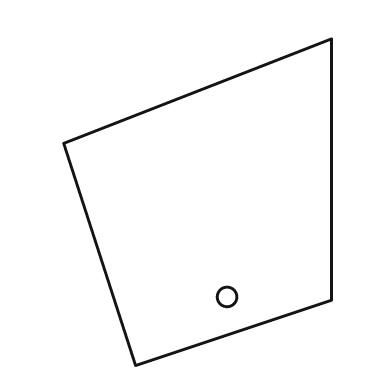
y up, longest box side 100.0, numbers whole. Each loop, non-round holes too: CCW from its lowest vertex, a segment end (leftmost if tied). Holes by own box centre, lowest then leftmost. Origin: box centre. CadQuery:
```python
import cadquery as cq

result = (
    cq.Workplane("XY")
    .moveTo(-19.0, -50.0)
    .lineTo(41.0, -30.0)
    .lineTo(41.0, 50.0)
    .lineTo(-41.0, 18.0)
    .close()
    .moveTo(9.0, -29.0)
    .circle(3.0)
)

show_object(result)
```